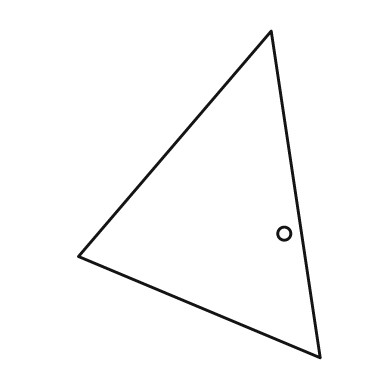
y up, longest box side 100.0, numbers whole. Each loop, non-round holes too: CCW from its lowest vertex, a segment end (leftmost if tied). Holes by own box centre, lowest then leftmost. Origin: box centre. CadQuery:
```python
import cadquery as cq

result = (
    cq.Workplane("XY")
    .moveTo(37.0, -50.0)
    .lineTo(22.0, 50.0)
    .lineTo(-37.0, -19.0)
    .close()
    .moveTo(26.0, -12.0)
    .circle(2.0)
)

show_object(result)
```